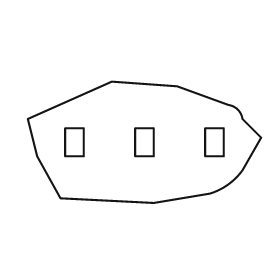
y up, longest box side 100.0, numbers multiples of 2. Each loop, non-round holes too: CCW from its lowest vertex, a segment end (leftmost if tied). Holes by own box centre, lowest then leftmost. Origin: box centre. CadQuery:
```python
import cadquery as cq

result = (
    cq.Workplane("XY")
    .moveTo(4.0, -26.0)
    .lineTo(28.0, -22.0)
    .threePointArc((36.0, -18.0), (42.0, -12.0))
    .lineTo(50.0, 2.0)
    .lineTo(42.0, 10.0)
    .threePointArc((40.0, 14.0), (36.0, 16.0))
    .lineTo(14.0, 24.0)
    .lineTo(-14.0, 26.0)
    .lineTo(-50.0, 10.0)
    .lineTo(-46.0, -6.0)
    .lineTo(-36.0, -24.0)
    .close()
    .moveTo(-34.0, -6.0)
    .lineTo(-26.0, -6.0)
    .lineTo(-26.0, 6.0)
    .lineTo(-34.0, 6.0)
    .close()
    .moveTo(-4.0, -6.0)
    .lineTo(4.0, -6.0)
    .lineTo(4.0, 6.0)
    .lineTo(-4.0, 6.0)
    .close()
    .moveTo(26.0, -6.0)
    .lineTo(34.0, -6.0)
    .lineTo(34.0, 6.0)
    .lineTo(26.0, 6.0)
    .close()
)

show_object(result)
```